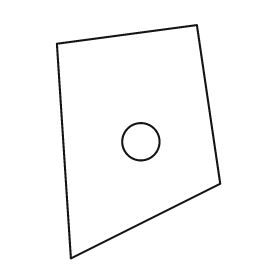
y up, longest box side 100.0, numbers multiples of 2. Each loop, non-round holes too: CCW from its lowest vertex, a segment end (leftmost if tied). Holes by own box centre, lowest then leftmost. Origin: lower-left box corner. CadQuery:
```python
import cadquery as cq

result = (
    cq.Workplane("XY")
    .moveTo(6.0, 0.0)
    .lineTo(70.0, 32.0)
    .lineTo(60.0, 100.0)
    .lineTo(0.0, 92.0)
    .close()
    .moveTo(36.0, 50.0)
    .circle(8.0)
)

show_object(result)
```